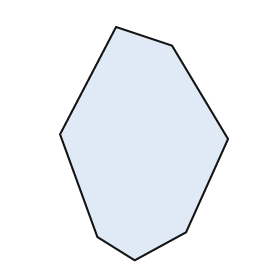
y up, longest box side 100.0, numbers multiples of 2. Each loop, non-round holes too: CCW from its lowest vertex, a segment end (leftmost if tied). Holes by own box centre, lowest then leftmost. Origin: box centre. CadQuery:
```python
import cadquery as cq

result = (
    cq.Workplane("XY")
    .moveTo(-4.0, -50.0)
    .lineTo(18.0, -38.0)
    .lineTo(36.0, 2.0)
    .lineTo(12.0, 42.0)
    .lineTo(-12.0, 50.0)
    .lineTo(-36.0, 4.0)
    .lineTo(-20.0, -40.0)
    .close()
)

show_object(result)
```